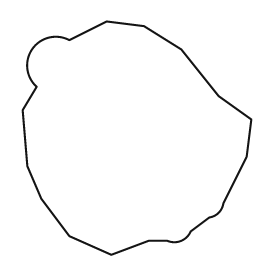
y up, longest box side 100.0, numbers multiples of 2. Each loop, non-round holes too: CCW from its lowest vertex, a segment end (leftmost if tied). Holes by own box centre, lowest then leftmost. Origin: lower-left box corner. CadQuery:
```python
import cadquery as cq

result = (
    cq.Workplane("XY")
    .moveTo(38.0, 0.0)
    .lineTo(54.0, 6.0)
    .lineTo(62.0, 6.0)
    .threePointArc((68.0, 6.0), (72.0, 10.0))
    .lineTo(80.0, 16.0)
    .threePointArc((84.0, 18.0), (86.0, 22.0))
    .lineTo(96.0, 42.0)
    .lineTo(98.0, 58.0)
    .lineTo(84.0, 68.0)
    .lineTo(68.0, 88.0)
    .lineTo(52.0, 98.0)
    .lineTo(36.0, 100.0)
    .lineTo(20.0, 92.0)
    .threePointArc((4.0, 88.0), (6.0, 72.0))
    .lineTo(0.0, 62.0)
    .lineTo(2.0, 38.0)
    .lineTo(8.0, 24.0)
    .lineTo(20.0, 8.0)
    .close()
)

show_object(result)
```